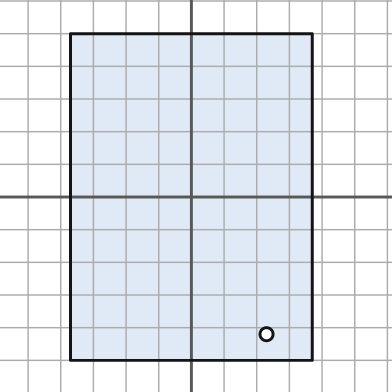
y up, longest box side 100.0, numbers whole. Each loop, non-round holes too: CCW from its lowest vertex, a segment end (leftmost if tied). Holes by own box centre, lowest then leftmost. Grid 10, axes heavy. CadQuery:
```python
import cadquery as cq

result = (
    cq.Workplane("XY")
    .moveTo(-37.0, -50.0)
    .lineTo(37.0, -50.0)
    .lineTo(37.0, 50.0)
    .lineTo(-37.0, 50.0)
    .close()
    .moveTo(23.0, -42.0)
    .circle(2.0)
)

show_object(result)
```